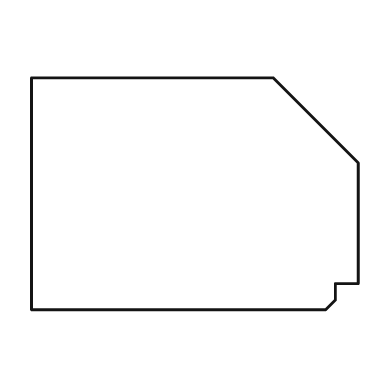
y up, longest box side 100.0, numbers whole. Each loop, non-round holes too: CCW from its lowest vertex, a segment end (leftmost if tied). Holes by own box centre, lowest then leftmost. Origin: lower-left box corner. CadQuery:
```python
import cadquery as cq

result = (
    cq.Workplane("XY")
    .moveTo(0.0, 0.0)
    .lineTo(90.0, 0.0)
    .lineTo(93.0, 3.0)
    .lineTo(93.0, 8.0)
    .lineTo(100.0, 8.0)
    .lineTo(100.0, 45.0)
    .lineTo(74.0, 71.0)
    .lineTo(0.0, 71.0)
    .close()
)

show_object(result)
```